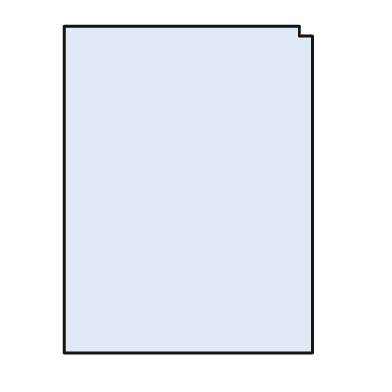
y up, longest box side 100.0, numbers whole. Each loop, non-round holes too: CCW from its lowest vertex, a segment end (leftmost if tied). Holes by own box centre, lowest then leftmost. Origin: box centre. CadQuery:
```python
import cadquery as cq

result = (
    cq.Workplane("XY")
    .moveTo(-38.0, -50.0)
    .lineTo(38.0, -50.0)
    .lineTo(38.0, 47.0)
    .lineTo(34.0, 47.0)
    .lineTo(34.0, 50.0)
    .lineTo(-38.0, 50.0)
    .close()
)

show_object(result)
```